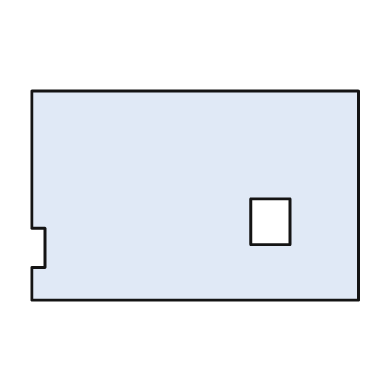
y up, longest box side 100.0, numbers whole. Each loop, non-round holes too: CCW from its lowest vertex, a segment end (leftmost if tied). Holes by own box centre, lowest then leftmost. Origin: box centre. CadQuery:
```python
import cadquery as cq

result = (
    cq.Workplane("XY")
    .moveTo(-50.0, -32.0)
    .lineTo(50.0, -32.0)
    .lineTo(50.0, 32.0)
    .lineTo(-50.0, 32.0)
    .lineTo(-50.0, -10.0)
    .lineTo(-46.0, -10.0)
    .lineTo(-46.0, -22.0)
    .lineTo(-50.0, -22.0)
    .close()
    .moveTo(17.0, -15.0)
    .lineTo(29.0, -15.0)
    .lineTo(29.0, -1.0)
    .lineTo(17.0, -1.0)
    .close()
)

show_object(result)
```